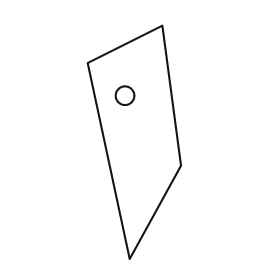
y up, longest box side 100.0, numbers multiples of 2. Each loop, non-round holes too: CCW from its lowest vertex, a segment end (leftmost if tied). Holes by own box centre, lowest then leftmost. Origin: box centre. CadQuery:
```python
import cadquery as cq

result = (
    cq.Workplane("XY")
    .moveTo(-2.0, -50.0)
    .lineTo(20.0, -10.0)
    .lineTo(12.0, 50.0)
    .lineTo(-20.0, 34.0)
    .close()
    .moveTo(-4.0, 20.0)
    .circle(4.0)
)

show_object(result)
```